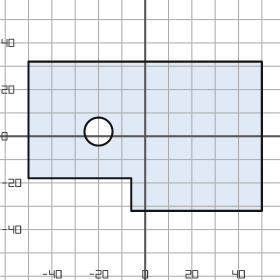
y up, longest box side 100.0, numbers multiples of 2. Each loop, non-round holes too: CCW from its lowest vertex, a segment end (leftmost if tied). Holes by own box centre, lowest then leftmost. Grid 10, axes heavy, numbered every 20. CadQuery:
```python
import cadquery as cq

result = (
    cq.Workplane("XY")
    .moveTo(-6.0, -32.0)
    .lineTo(50.0, -32.0)
    .lineTo(50.0, 32.0)
    .lineTo(-50.0, 32.0)
    .lineTo(-50.0, -18.0)
    .lineTo(-6.0, -18.0)
    .close()
    .moveTo(-20.0, 2.0)
    .circle(6.0)
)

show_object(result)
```